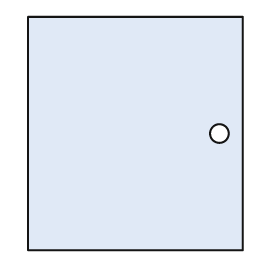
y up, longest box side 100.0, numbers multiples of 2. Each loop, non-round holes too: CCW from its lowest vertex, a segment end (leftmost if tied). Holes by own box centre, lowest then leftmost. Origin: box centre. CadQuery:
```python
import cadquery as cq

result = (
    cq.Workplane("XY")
    .moveTo(-46.0, -50.0)
    .lineTo(46.0, -50.0)
    .lineTo(46.0, 50.0)
    .lineTo(-46.0, 50.0)
    .close()
    .moveTo(36.0, 0.0)
    .circle(4.0)
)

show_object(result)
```